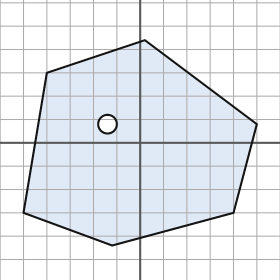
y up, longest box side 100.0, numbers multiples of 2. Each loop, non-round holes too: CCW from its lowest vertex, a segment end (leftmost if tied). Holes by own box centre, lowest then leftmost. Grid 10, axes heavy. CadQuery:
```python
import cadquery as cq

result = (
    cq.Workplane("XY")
    .moveTo(-12.0, -44.0)
    .lineTo(40.0, -30.0)
    .lineTo(50.0, 8.0)
    .lineTo(2.0, 44.0)
    .lineTo(-40.0, 30.0)
    .lineTo(-50.0, -30.0)
    .close()
    .moveTo(-14.0, 8.0)
    .circle(4.0)
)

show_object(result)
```